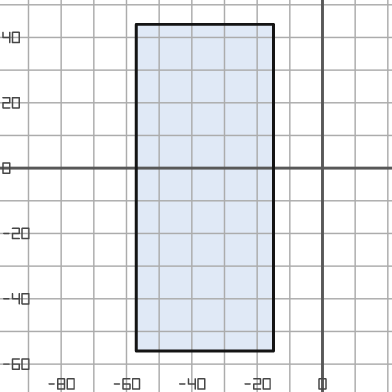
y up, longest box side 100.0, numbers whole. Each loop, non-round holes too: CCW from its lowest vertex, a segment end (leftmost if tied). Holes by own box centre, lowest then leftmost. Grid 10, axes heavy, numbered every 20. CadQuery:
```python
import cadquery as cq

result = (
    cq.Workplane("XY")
    .moveTo(-57.0, -56.0)
    .lineTo(-15.0, -56.0)
    .lineTo(-15.0, 44.0)
    .lineTo(-57.0, 44.0)
    .close()
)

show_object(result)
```